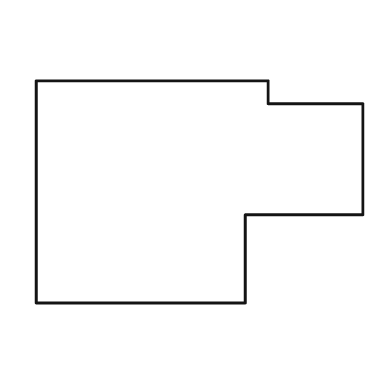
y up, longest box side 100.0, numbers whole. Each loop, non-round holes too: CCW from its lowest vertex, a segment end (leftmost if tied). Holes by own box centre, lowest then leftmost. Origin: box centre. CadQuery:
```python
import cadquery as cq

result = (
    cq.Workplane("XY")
    .moveTo(-50.0, -34.0)
    .lineTo(14.0, -34.0)
    .lineTo(14.0, -7.0)
    .lineTo(50.0, -7.0)
    .lineTo(50.0, 27.0)
    .lineTo(21.0, 27.0)
    .lineTo(21.0, 34.0)
    .lineTo(-50.0, 34.0)
    .close()
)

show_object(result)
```